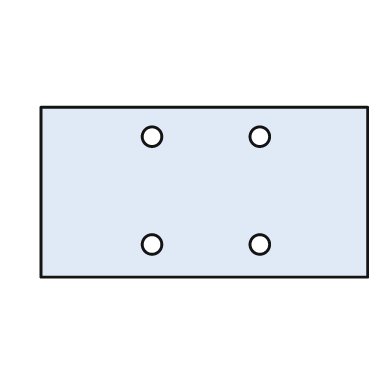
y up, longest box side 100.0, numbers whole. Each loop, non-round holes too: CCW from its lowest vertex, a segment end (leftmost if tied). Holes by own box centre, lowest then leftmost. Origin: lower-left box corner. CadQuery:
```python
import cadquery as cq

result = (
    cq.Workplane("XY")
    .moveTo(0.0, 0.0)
    .lineTo(100.0, 0.0)
    .lineTo(100.0, 52.0)
    .lineTo(0.0, 52.0)
    .close()
    .moveTo(34.0, 10.0)
    .circle(3.0)
    .moveTo(67.0, 10.0)
    .circle(3.0)
    .moveTo(34.0, 43.0)
    .circle(3.0)
    .moveTo(67.0, 43.0)
    .circle(3.0)
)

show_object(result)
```